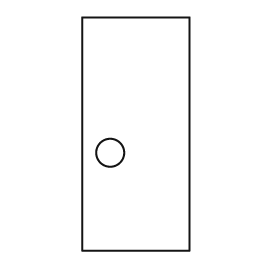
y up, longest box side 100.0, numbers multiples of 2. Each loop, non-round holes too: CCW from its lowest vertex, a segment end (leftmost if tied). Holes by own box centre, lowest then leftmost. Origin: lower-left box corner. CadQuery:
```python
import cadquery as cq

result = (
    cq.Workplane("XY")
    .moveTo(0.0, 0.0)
    .lineTo(46.0, 0.0)
    .lineTo(46.0, 100.0)
    .lineTo(0.0, 100.0)
    .close()
    .moveTo(12.0, 42.0)
    .circle(6.0)
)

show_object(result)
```